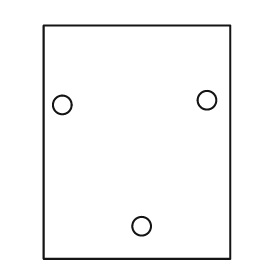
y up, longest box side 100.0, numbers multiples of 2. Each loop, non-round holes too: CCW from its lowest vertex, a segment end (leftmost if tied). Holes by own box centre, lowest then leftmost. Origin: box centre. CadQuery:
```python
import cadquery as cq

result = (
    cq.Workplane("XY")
    .moveTo(-40.0, -50.0)
    .lineTo(40.0, -50.0)
    .lineTo(40.0, 50.0)
    .lineTo(-40.0, 50.0)
    .close()
    .moveTo(2.0, -36.0)
    .circle(4.0)
    .moveTo(-32.0, 16.0)
    .circle(4.0)
    .moveTo(30.0, 18.0)
    .circle(4.0)
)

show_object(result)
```